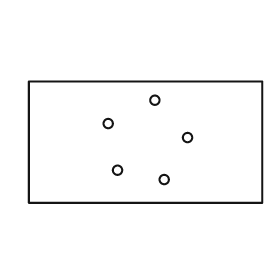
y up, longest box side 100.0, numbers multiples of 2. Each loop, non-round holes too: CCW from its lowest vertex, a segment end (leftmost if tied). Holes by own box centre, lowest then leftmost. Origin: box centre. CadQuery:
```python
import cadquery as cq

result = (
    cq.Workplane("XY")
    .moveTo(-50.0, -26.0)
    .lineTo(50.0, -26.0)
    .lineTo(50.0, 26.0)
    .lineTo(-50.0, 26.0)
    .close()
    .moveTo(8.0, -16.0)
    .circle(2.0)
    .moveTo(-12.0, -12.0)
    .circle(2.0)
    .moveTo(18.0, 2.0)
    .circle(2.0)
    .moveTo(-16.0, 8.0)
    .circle(2.0)
    .moveTo(4.0, 18.0)
    .circle(2.0)
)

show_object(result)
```